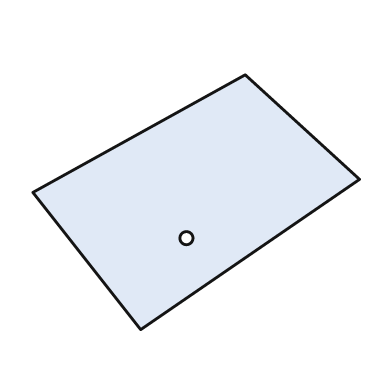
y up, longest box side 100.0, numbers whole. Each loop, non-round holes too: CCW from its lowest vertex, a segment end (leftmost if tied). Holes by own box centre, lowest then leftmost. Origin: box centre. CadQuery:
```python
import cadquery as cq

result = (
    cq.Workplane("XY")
    .moveTo(-17.0, -39.0)
    .lineTo(50.0, 7.0)
    .lineTo(15.0, 39.0)
    .lineTo(-50.0, 3.0)
    .close()
    .moveTo(-3.0, -11.0)
    .circle(2.0)
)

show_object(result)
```